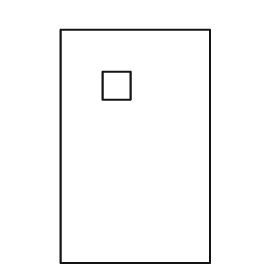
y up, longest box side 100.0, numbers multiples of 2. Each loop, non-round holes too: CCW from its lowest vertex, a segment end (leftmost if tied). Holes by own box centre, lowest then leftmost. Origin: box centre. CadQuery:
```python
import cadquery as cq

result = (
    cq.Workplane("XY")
    .moveTo(-32.0, -50.0)
    .lineTo(32.0, -50.0)
    .lineTo(32.0, 50.0)
    .lineTo(-32.0, 50.0)
    .close()
    .moveTo(-14.0, 20.0)
    .lineTo(-2.0, 20.0)
    .lineTo(-2.0, 32.0)
    .lineTo(-14.0, 32.0)
    .close()
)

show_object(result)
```